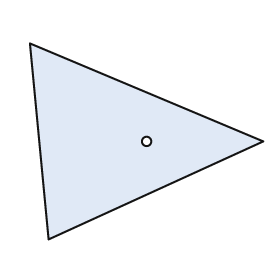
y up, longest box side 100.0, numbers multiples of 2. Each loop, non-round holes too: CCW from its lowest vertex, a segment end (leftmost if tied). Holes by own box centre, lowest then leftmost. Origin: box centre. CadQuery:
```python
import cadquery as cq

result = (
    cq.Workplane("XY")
    .moveTo(-42.0, -42.0)
    .lineTo(50.0, 0.0)
    .lineTo(-50.0, 42.0)
    .close()
    .moveTo(0.0, 0.0)
    .circle(2.0)
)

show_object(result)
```